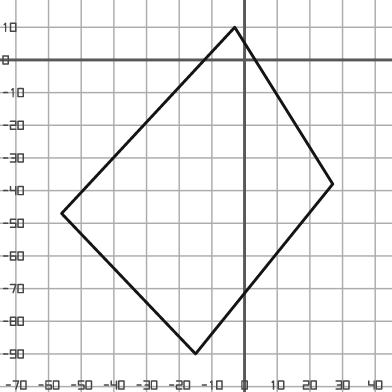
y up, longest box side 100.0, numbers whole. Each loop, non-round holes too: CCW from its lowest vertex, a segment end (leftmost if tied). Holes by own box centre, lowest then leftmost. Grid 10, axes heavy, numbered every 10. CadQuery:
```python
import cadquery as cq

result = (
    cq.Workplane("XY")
    .moveTo(-15.0, -90.0)
    .lineTo(27.0, -38.0)
    .lineTo(-3.0, 10.0)
    .lineTo(-56.0, -47.0)
    .close()
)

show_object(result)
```